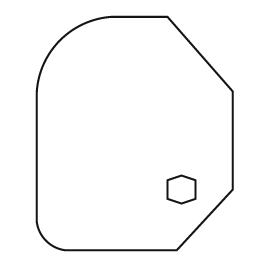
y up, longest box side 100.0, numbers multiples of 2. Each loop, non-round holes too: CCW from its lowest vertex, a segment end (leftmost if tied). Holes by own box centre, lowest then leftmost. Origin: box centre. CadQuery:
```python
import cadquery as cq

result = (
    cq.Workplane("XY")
    .moveTo(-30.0, -50.0)
    .lineTo(18.0, -50.0)
    .lineTo(42.0, -24.0)
    .lineTo(42.0, 18.0)
    .lineTo(14.0, 50.0)
    .lineTo(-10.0, 50.0)
    .threePointArc((-32.0, 40.0), (-42.0, 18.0))
    .lineTo(-42.0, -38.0)
    .threePointArc((-38.0, -46.0), (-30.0, -50.0))
    .close()
    .moveTo(20.0, -30.0)
    .lineTo(26.0, -28.0)
    .lineTo(26.0, -20.0)
    .lineTo(20.0, -18.0)
    .lineTo(14.0, -20.0)
    .lineTo(14.0, -28.0)
    .close()
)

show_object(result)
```